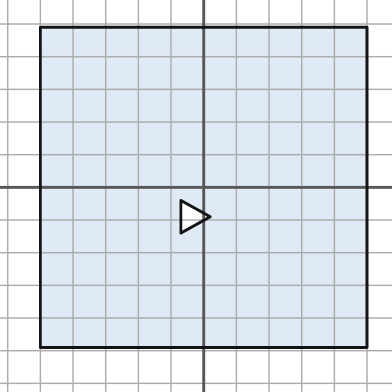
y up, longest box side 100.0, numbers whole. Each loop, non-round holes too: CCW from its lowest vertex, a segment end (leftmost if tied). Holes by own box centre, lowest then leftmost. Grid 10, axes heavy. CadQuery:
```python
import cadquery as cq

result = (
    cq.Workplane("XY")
    .moveTo(-50.0, -49.0)
    .lineTo(50.0, -49.0)
    .lineTo(50.0, 49.0)
    .lineTo(-50.0, 49.0)
    .close()
    .moveTo(-7.0, -14.0)
    .lineTo(2.0, -9.0)
    .lineTo(-7.0, -4.0)
    .close()
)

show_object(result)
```